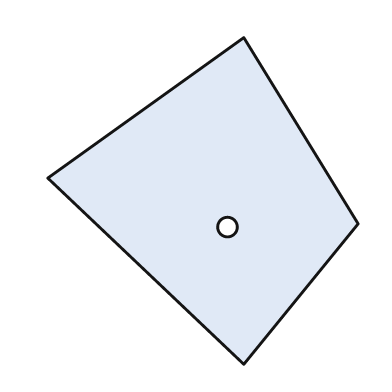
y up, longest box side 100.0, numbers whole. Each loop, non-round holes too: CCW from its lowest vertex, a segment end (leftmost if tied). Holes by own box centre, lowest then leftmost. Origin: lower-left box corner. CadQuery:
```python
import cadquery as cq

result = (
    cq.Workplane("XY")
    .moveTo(60.0, 0.0)
    .lineTo(95.0, 43.0)
    .lineTo(60.0, 100.0)
    .lineTo(0.0, 57.0)
    .close()
    .moveTo(55.0, 42.0)
    .circle(3.0)
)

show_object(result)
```